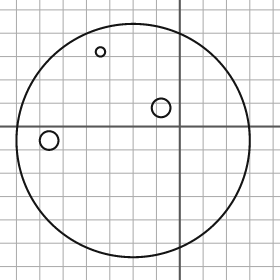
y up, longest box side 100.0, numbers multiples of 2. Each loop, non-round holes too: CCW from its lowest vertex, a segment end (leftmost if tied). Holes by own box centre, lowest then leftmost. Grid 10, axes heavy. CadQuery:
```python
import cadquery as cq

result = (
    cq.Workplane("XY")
    .moveTo(-20.0, -6.0)
    .circle(50.0)
    .moveTo(-56.0, -6.0)
    .circle(4.0)
    .moveTo(-8.0, 8.0)
    .circle(4.0)
    .moveTo(-34.0, 32.0)
    .circle(2.0)
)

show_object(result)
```